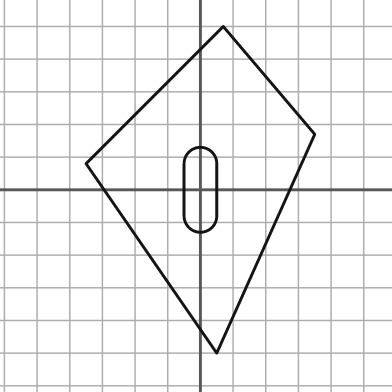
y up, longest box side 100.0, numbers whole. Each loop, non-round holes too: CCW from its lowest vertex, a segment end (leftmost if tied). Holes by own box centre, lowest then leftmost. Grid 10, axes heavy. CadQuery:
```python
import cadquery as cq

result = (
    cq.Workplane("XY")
    .moveTo(5.0, -50.0)
    .lineTo(35.0, 17.0)
    .lineTo(7.0, 50.0)
    .lineTo(-35.0, 8.0)
    .close()
    .moveTo(-5.0, -8.0)
    .threePointArc((0.0, -13.0), (5.0, -8.0))
    .lineTo(5.0, 8.0)
    .threePointArc((0.0, 13.0), (-5.0, 8.0))
    .close()
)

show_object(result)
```